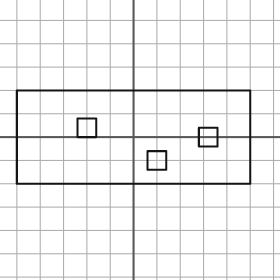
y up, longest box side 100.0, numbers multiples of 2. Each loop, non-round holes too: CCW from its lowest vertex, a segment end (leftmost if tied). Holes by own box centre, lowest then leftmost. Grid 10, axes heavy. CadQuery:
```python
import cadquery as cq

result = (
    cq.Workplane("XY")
    .moveTo(-50.0, -20.0)
    .lineTo(50.0, -20.0)
    .lineTo(50.0, 20.0)
    .lineTo(-50.0, 20.0)
    .close()
    .moveTo(6.0, -14.0)
    .lineTo(14.0, -14.0)
    .lineTo(14.0, -6.0)
    .lineTo(6.0, -6.0)
    .close()
    .moveTo(28.0, -4.0)
    .lineTo(36.0, -4.0)
    .lineTo(36.0, 4.0)
    .lineTo(28.0, 4.0)
    .close()
    .moveTo(-24.0, 0.0)
    .lineTo(-16.0, 0.0)
    .lineTo(-16.0, 8.0)
    .lineTo(-24.0, 8.0)
    .close()
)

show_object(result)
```